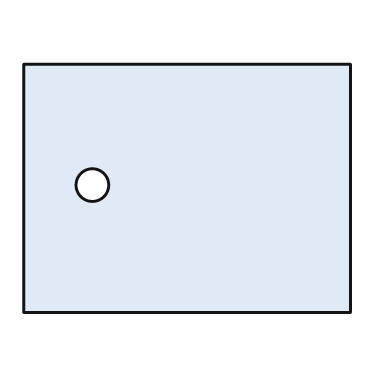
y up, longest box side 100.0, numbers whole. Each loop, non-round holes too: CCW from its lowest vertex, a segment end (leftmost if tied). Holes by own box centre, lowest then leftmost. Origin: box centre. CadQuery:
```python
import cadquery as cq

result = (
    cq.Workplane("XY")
    .moveTo(-50.0, -38.0)
    .lineTo(50.0, -38.0)
    .lineTo(50.0, 38.0)
    .lineTo(-50.0, 38.0)
    .close()
    .moveTo(-29.0, 1.0)
    .circle(5.0)
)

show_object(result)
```